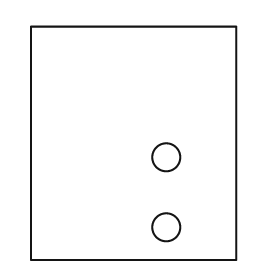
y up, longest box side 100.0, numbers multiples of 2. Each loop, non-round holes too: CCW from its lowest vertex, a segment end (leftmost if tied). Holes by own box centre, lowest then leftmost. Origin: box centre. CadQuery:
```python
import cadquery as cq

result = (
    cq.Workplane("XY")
    .moveTo(-44.0, -50.0)
    .lineTo(44.0, -50.0)
    .lineTo(44.0, 50.0)
    .lineTo(-44.0, 50.0)
    .close()
    .moveTo(14.0, -36.0)
    .circle(6.0)
    .moveTo(14.0, -6.0)
    .circle(6.0)
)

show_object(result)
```